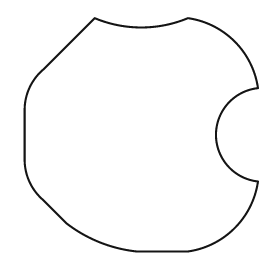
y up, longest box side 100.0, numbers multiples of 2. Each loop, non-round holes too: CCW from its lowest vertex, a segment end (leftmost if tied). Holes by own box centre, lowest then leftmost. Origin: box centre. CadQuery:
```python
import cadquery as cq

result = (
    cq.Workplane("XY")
    .moveTo(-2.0, -50.0)
    .lineTo(20.0, -50.0)
    .threePointArc((40.0, -40.0), (50.0, -20.0))
    .threePointArc((32.0, 0.0), (50.0, 20.0))
    .threePointArc((40.0, 40.0), (20.0, 50.0))
    .threePointArc((0.0, 46.0), (-20.0, 50.0))
    .lineTo(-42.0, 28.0)
    .threePointArc((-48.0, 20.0), (-50.0, 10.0))
    .lineTo(-50.0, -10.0)
    .threePointArc((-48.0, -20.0), (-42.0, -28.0))
    .lineTo(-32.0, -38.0)
    .threePointArc((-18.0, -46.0), (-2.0, -50.0))
    .close()
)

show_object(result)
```